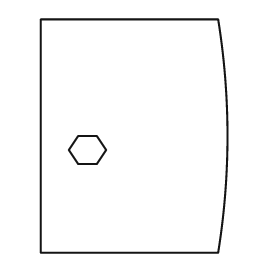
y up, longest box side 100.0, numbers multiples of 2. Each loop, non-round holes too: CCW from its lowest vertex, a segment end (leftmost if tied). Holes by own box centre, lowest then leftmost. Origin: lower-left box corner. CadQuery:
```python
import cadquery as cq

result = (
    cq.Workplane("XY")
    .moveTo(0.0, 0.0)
    .lineTo(76.0, 0.0)
    .threePointArc((80.0, 50.0), (76.0, 100.0))
    .lineTo(0.0, 100.0)
    .close()
    .moveTo(16.0, 38.0)
    .lineTo(24.0, 38.0)
    .lineTo(28.0, 44.0)
    .lineTo(24.0, 50.0)
    .lineTo(16.0, 50.0)
    .lineTo(12.0, 44.0)
    .close()
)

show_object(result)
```